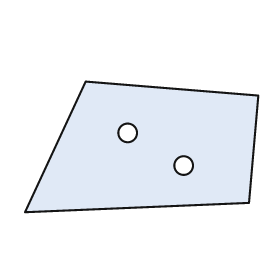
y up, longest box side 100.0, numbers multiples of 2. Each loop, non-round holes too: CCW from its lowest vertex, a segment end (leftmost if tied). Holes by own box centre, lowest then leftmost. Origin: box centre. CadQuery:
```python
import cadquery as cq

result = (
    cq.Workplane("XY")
    .moveTo(-50.0, -28.0)
    .lineTo(46.0, -24.0)
    .lineTo(50.0, 22.0)
    .lineTo(-24.0, 28.0)
    .close()
    .moveTo(18.0, -8.0)
    .circle(4.0)
    .moveTo(-6.0, 6.0)
    .circle(4.0)
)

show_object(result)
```